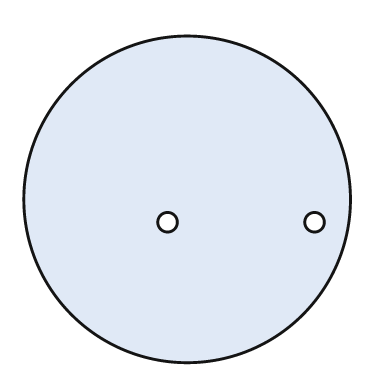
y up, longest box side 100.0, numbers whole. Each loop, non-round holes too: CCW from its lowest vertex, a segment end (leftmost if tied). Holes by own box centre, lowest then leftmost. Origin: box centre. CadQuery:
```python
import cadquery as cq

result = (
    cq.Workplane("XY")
    .moveTo(0.0, 0.0)
    .circle(50.0)
    .moveTo(-6.0, -7.0)
    .circle(3.0)
    .moveTo(39.0, -7.0)
    .circle(3.0)
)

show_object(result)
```